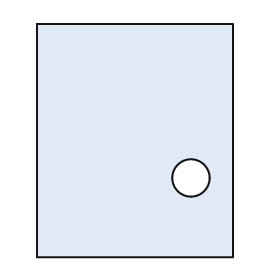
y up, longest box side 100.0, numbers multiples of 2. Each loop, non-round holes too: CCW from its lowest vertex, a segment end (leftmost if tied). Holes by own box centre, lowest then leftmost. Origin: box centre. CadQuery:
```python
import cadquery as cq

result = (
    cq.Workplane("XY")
    .moveTo(-42.0, -50.0)
    .lineTo(42.0, -50.0)
    .lineTo(42.0, 50.0)
    .lineTo(-42.0, 50.0)
    .close()
    .moveTo(24.0, -16.0)
    .circle(8.0)
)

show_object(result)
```